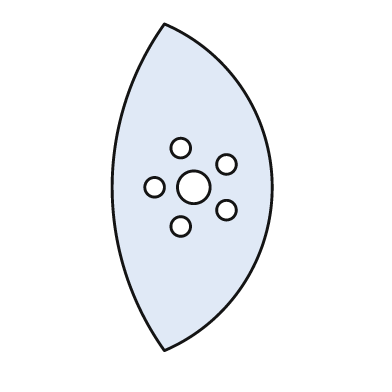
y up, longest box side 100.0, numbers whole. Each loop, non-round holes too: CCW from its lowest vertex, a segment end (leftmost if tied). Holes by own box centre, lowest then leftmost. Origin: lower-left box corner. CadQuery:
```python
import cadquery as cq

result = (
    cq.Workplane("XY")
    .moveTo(16.0, 0.0)
    .threePointArc((49.0, 50.0), (16.0, 100.0))
    .threePointArc((0.0, 50.0), (16.0, 0.0))
    .close()
    .moveTo(21.0, 38.0)
    .circle(3.0)
    .moveTo(35.0, 43.0)
    .circle(3.0)
    .moveTo(13.0, 50.0)
    .circle(3.0)
    .moveTo(25.0, 50.0)
    .circle(5.0)
    .moveTo(35.0, 57.0)
    .circle(3.0)
    .moveTo(21.0, 62.0)
    .circle(3.0)
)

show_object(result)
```